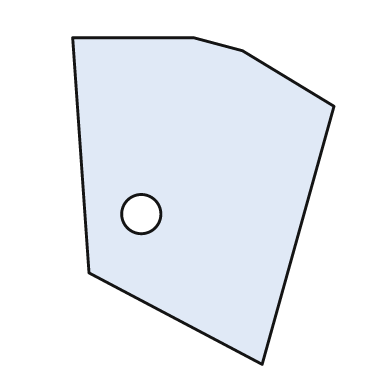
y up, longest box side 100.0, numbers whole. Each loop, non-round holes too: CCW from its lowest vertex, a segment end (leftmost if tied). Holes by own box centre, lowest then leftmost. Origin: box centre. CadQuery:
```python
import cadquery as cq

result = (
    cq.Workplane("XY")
    .moveTo(18.0, -50.0)
    .lineTo(40.0, 29.0)
    .lineTo(12.0, 46.0)
    .lineTo(-3.0, 50.0)
    .lineTo(-40.0, 50.0)
    .lineTo(-35.0, -22.0)
    .close()
    .moveTo(-19.0, -4.0)
    .circle(6.0)
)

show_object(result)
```